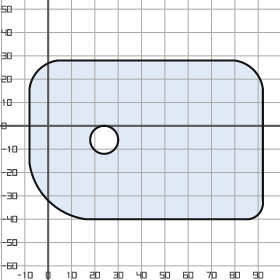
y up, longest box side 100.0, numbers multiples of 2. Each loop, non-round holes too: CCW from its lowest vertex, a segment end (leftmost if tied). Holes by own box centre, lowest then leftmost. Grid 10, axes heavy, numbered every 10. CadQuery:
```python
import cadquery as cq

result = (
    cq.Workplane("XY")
    .moveTo(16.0, -40.0)
    .lineTo(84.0, -40.0)
    .threePointArc((90.0, -38.0), (92.0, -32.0))
    .lineTo(92.0, 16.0)
    .threePointArc((88.0, 24.0), (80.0, 28.0))
    .lineTo(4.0, 28.0)
    .threePointArc((-4.0, 24.0), (-8.0, 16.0))
    .lineTo(-8.0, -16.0)
    .threePointArc((0.0, -32.0), (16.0, -40.0))
    .close()
    .moveTo(24.0, -6.0)
    .circle(6.0)
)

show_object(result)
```